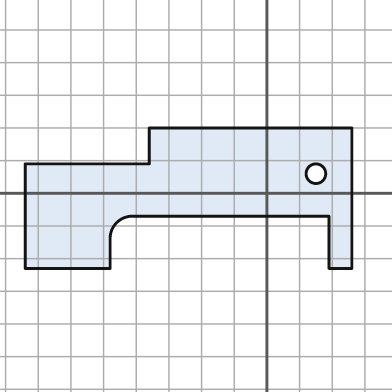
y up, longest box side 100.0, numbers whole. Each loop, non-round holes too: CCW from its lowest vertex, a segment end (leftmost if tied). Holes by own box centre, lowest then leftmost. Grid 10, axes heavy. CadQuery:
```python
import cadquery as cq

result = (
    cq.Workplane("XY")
    .moveTo(-74.0, -23.0)
    .lineTo(-48.0, -23.0)
    .lineTo(-48.0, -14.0)
    .threePointArc((-46.0, -9.0), (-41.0, -7.0))
    .lineTo(19.0, -7.0)
    .lineTo(19.0, -23.0)
    .lineTo(26.0, -23.0)
    .lineTo(26.0, 20.0)
    .lineTo(-36.0, 20.0)
    .lineTo(-36.0, 9.0)
    .lineTo(-74.0, 9.0)
    .close()
    .moveTo(15.0, 6.0)
    .circle(3.0)
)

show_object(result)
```